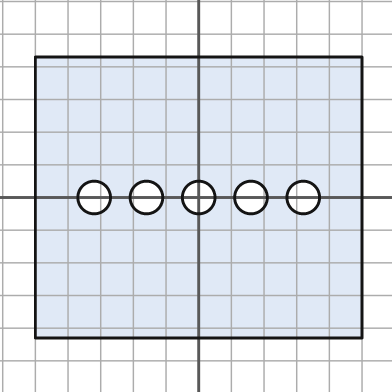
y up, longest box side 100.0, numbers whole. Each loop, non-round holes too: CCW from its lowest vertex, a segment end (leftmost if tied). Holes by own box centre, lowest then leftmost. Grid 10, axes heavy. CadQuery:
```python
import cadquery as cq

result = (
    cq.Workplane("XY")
    .moveTo(-50.0, -43.0)
    .lineTo(50.0, -43.0)
    .lineTo(50.0, 43.0)
    .lineTo(-50.0, 43.0)
    .close()
    .moveTo(-32.0, 0.0)
    .circle(5.0)
    .moveTo(-16.0, 0.0)
    .circle(5.0)
    .moveTo(0.0, 0.0)
    .circle(5.0)
    .moveTo(16.0, 0.0)
    .circle(5.0)
    .moveTo(32.0, 0.0)
    .circle(5.0)
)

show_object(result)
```